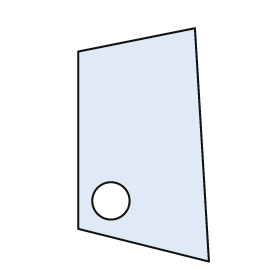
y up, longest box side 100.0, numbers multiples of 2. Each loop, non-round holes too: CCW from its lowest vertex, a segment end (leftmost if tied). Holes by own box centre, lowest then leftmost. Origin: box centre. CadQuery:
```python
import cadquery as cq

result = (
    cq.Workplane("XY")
    .moveTo(28.0, -50.0)
    .lineTo(22.0, 50.0)
    .lineTo(-28.0, 40.0)
    .lineTo(-28.0, -36.0)
    .close()
    .moveTo(-14.0, -24.0)
    .circle(8.0)
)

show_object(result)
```